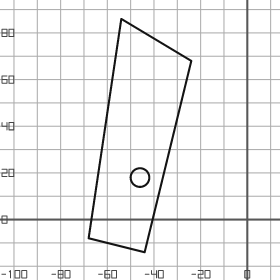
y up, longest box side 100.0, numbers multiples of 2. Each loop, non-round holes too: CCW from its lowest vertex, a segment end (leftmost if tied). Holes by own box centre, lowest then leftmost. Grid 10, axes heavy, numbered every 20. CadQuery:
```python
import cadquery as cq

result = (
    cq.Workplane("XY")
    .moveTo(-44.0, -14.0)
    .lineTo(-24.0, 68.0)
    .lineTo(-54.0, 86.0)
    .lineTo(-68.0, -8.0)
    .close()
    .moveTo(-46.0, 18.0)
    .circle(4.0)
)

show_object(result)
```